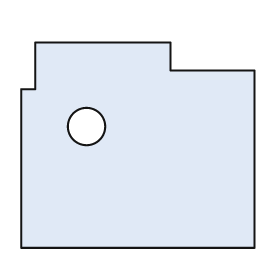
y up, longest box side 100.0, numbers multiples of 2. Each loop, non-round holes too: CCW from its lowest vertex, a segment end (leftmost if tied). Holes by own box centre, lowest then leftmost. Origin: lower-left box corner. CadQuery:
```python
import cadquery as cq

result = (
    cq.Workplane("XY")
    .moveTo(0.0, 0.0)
    .lineTo(100.0, 0.0)
    .lineTo(100.0, 76.0)
    .lineTo(64.0, 76.0)
    .lineTo(64.0, 88.0)
    .lineTo(6.0, 88.0)
    .lineTo(6.0, 68.0)
    .lineTo(0.0, 68.0)
    .close()
    .moveTo(28.0, 52.0)
    .circle(8.0)
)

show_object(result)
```